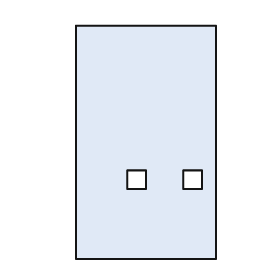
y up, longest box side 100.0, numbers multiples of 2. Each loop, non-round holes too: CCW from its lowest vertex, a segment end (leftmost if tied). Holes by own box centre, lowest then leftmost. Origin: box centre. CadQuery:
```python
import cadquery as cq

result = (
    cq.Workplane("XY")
    .moveTo(-30.0, -50.0)
    .lineTo(30.0, -50.0)
    .lineTo(30.0, 50.0)
    .lineTo(-30.0, 50.0)
    .close()
    .moveTo(-8.0, -20.0)
    .lineTo(0.0, -20.0)
    .lineTo(0.0, -12.0)
    .lineTo(-8.0, -12.0)
    .close()
    .moveTo(16.0, -20.0)
    .lineTo(24.0, -20.0)
    .lineTo(24.0, -12.0)
    .lineTo(16.0, -12.0)
    .close()
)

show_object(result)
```